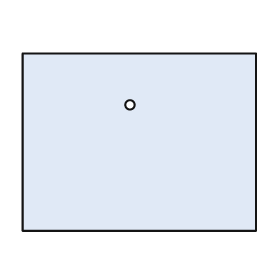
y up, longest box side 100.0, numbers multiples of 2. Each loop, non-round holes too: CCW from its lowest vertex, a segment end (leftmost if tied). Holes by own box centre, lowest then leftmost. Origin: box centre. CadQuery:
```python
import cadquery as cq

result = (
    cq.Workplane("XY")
    .moveTo(-50.0, -38.0)
    .lineTo(50.0, -38.0)
    .lineTo(50.0, 38.0)
    .lineTo(-50.0, 38.0)
    .close()
    .moveTo(-4.0, 16.0)
    .circle(2.0)
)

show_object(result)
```